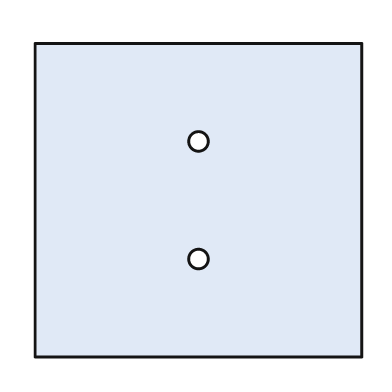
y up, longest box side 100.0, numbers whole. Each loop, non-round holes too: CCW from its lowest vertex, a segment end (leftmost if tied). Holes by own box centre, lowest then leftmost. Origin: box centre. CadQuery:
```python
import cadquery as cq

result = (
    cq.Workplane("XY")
    .moveTo(-50.0, -48.0)
    .lineTo(50.0, -48.0)
    .lineTo(50.0, 48.0)
    .lineTo(-50.0, 48.0)
    .close()
    .moveTo(0.0, -18.0)
    .circle(3.0)
    .moveTo(0.0, 18.0)
    .circle(3.0)
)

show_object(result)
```